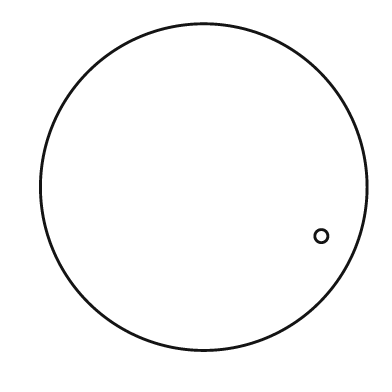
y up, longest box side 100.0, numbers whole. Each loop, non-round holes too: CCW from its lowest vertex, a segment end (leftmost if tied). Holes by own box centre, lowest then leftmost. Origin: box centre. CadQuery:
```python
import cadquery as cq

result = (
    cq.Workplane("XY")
    .moveTo(0.0, 0.0)
    .circle(50.0)
    .moveTo(36.0, -15.0)
    .circle(2.0)
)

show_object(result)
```